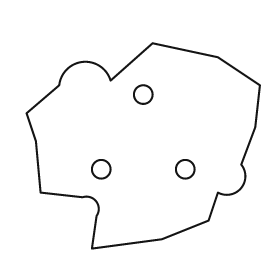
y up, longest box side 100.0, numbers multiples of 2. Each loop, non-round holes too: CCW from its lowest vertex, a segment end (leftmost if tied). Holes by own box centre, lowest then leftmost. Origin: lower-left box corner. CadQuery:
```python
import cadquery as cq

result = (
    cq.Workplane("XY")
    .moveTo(28.0, 0.0)
    .lineTo(58.0, 4.0)
    .lineTo(78.0, 12.0)
    .lineTo(82.0, 24.0)
    .threePointArc((92.0, 26.0), (92.0, 36.0))
    .lineTo(98.0, 52.0)
    .lineTo(100.0, 70.0)
    .lineTo(82.0, 82.0)
    .lineTo(54.0, 88.0)
    .lineTo(36.0, 72.0)
    .threePointArc((24.0, 80.0), (14.0, 70.0))
    .lineTo(0.0, 58.0)
    .lineTo(4.0, 46.0)
    .lineTo(6.0, 24.0)
    .lineTo(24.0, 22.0)
    .threePointArc((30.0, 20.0), (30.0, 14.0))
    .close()
    .moveTo(32.0, 34.0)
    .circle(4.0)
    .moveTo(68.0, 34.0)
    .circle(4.0)
    .moveTo(50.0, 66.0)
    .circle(4.0)
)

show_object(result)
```